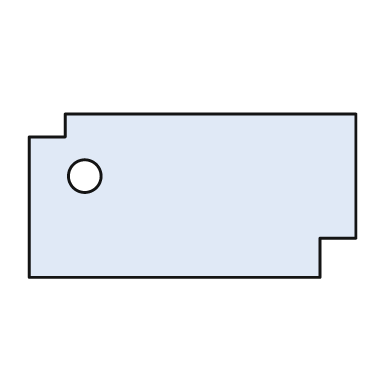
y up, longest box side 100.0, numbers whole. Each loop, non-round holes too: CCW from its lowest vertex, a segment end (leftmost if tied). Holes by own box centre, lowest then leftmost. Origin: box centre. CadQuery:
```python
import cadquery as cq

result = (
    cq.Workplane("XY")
    .moveTo(-50.0, -25.0)
    .lineTo(39.0, -25.0)
    .lineTo(39.0, -13.0)
    .lineTo(50.0, -13.0)
    .lineTo(50.0, 25.0)
    .lineTo(-39.0, 25.0)
    .lineTo(-39.0, 18.0)
    .lineTo(-50.0, 18.0)
    .close()
    .moveTo(-33.0, 6.0)
    .circle(5.0)
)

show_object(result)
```